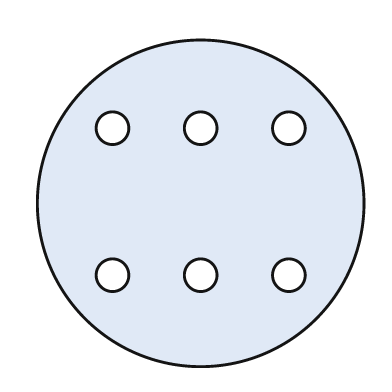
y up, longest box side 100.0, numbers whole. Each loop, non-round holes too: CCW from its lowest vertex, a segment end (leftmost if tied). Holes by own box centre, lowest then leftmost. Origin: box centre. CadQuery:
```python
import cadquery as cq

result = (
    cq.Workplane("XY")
    .moveTo(0.0, 0.0)
    .circle(50.0)
    .moveTo(-27.0, -22.0)
    .circle(5.0)
    .moveTo(0.0, -22.0)
    .circle(5.0)
    .moveTo(27.0, -22.0)
    .circle(5.0)
    .moveTo(-27.0, 23.0)
    .circle(5.0)
    .moveTo(0.0, 23.0)
    .circle(5.0)
    .moveTo(27.0, 23.0)
    .circle(5.0)
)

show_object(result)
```